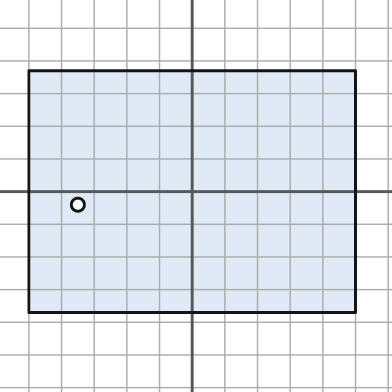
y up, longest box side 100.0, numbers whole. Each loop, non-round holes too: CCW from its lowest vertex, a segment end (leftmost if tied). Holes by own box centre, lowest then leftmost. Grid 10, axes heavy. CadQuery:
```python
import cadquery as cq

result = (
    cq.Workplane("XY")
    .moveTo(-50.0, -37.0)
    .lineTo(50.0, -37.0)
    .lineTo(50.0, 37.0)
    .lineTo(-50.0, 37.0)
    .close()
    .moveTo(-35.0, -4.0)
    .circle(2.0)
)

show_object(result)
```